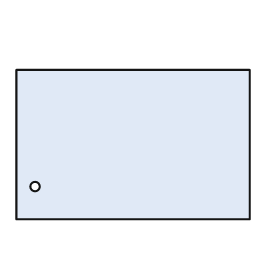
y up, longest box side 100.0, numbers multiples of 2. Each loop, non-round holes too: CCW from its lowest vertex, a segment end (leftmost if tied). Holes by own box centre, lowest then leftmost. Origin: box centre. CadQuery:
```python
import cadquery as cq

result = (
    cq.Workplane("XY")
    .moveTo(-50.0, -32.0)
    .lineTo(50.0, -32.0)
    .lineTo(50.0, 32.0)
    .lineTo(-50.0, 32.0)
    .close()
    .moveTo(-42.0, -18.0)
    .circle(2.0)
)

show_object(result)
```